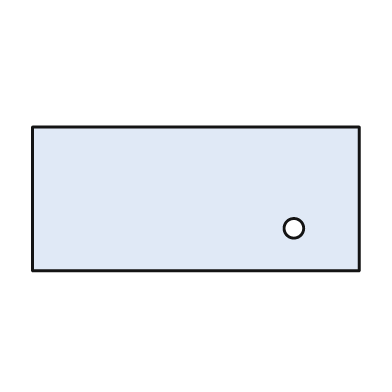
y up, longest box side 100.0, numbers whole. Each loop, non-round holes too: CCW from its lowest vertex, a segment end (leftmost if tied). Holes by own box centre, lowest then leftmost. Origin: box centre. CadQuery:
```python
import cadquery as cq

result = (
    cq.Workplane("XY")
    .moveTo(-50.0, -22.0)
    .lineTo(50.0, -22.0)
    .lineTo(50.0, 22.0)
    .lineTo(-50.0, 22.0)
    .close()
    .moveTo(30.0, -9.0)
    .circle(3.0)
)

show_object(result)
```